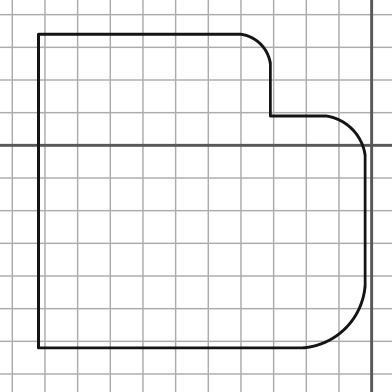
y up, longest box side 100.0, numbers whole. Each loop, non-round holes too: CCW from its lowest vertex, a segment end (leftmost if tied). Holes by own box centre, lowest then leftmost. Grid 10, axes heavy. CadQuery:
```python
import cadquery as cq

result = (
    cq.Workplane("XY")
    .moveTo(-102.0, -62.0)
    .lineTo(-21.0, -62.0)
    .threePointArc((-8.0, -56.0), (-2.0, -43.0))
    .lineTo(-2.0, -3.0)
    .threePointArc((-6.0, 5.0), (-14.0, 9.0))
    .lineTo(-31.0, 9.0)
    .lineTo(-31.0, 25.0)
    .threePointArc((-34.0, 31.0), (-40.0, 34.0))
    .lineTo(-102.0, 34.0)
    .close()
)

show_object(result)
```